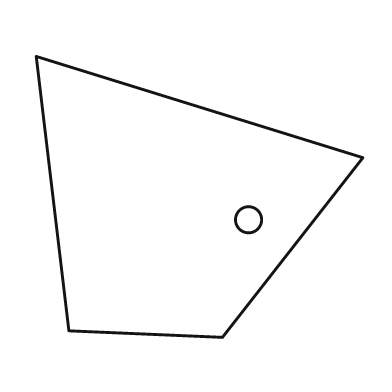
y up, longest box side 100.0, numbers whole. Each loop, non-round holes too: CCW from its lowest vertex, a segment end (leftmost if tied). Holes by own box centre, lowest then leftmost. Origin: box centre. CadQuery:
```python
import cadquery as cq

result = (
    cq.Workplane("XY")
    .moveTo(7.0, -43.0)
    .lineTo(50.0, 12.0)
    .lineTo(-50.0, 43.0)
    .lineTo(-40.0, -41.0)
    .close()
    .moveTo(15.0, -7.0)
    .circle(4.0)
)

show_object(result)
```